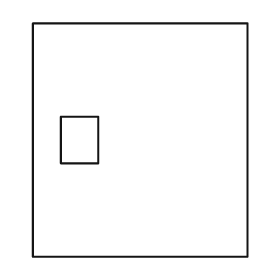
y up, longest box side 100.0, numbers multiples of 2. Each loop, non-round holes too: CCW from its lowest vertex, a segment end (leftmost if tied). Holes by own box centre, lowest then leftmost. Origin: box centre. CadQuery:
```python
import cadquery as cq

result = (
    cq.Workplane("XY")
    .moveTo(-46.0, -50.0)
    .lineTo(46.0, -50.0)
    .lineTo(46.0, 50.0)
    .lineTo(-46.0, 50.0)
    .close()
    .moveTo(-34.0, -10.0)
    .lineTo(-18.0, -10.0)
    .lineTo(-18.0, 10.0)
    .lineTo(-34.0, 10.0)
    .close()
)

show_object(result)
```